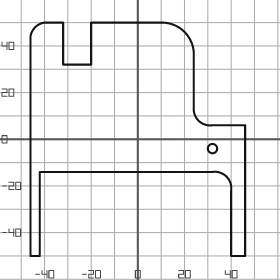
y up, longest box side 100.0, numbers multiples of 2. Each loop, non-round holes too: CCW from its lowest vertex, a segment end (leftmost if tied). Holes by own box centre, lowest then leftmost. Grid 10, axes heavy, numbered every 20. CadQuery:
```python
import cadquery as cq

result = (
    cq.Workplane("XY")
    .moveTo(-46.0, -50.0)
    .lineTo(-42.0, -50.0)
    .lineTo(-42.0, -14.0)
    .lineTo(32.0, -14.0)
    .threePointArc((38.0, -16.0), (40.0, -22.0))
    .lineTo(40.0, -50.0)
    .lineTo(46.0, -50.0)
    .lineTo(46.0, 6.0)
    .lineTo(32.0, 6.0)
    .threePointArc((26.0, 8.0), (24.0, 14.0))
    .lineTo(24.0, 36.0)
    .threePointArc((20.0, 46.0), (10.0, 50.0))
    .lineTo(-20.0, 50.0)
    .lineTo(-20.0, 32.0)
    .lineTo(-32.0, 32.0)
    .lineTo(-32.0, 50.0)
    .lineTo(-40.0, 50.0)
    .threePointArc((-44.0, 48.0), (-46.0, 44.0))
    .close()
    .moveTo(32.0, -4.0)
    .circle(2.0)
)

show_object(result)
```